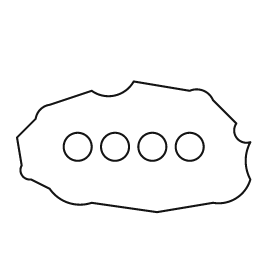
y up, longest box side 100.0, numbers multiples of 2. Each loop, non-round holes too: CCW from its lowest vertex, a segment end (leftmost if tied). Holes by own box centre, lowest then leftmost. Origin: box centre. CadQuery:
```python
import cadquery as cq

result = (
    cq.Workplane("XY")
    .moveTo(10.0, -28.0)
    .lineTo(34.0, -24.0)
    .threePointArc((44.0, -22.0), (50.0, -14.0))
    .threePointArc((48.0, -6.0), (50.0, 2.0))
    .threePointArc((44.0, 4.0), (44.0, 10.0))
    .lineTo(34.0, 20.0)
    .threePointArc((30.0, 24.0), (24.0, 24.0))
    .lineTo(0.0, 28.0)
    .threePointArc((-8.0, 22.0), (-18.0, 24.0))
    .lineTo(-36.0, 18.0)
    .threePointArc((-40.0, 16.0), (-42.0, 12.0))
    .lineTo(-50.0, 4.0)
    .lineTo(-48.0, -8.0)
    .threePointArc((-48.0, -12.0), (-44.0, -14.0))
    .lineTo(-36.0, -18.0)
    .threePointArc((-28.0, -24.0), (-18.0, -24.0))
    .close()
    .moveTo(-24.0, 0.0)
    .circle(6.0)
    .moveTo(-8.0, 0.0)
    .circle(6.0)
    .moveTo(8.0, 0.0)
    .circle(6.0)
    .moveTo(24.0, 0.0)
    .circle(6.0)
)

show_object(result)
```